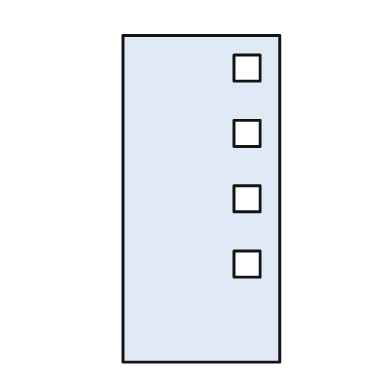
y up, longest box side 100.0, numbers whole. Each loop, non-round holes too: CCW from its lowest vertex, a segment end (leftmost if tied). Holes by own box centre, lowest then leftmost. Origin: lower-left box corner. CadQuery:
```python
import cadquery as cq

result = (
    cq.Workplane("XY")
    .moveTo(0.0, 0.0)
    .lineTo(48.0, 0.0)
    .lineTo(48.0, 100.0)
    .lineTo(0.0, 100.0)
    .close()
    .moveTo(34.0, 26.0)
    .lineTo(42.0, 26.0)
    .lineTo(42.0, 34.0)
    .lineTo(34.0, 34.0)
    .close()
    .moveTo(34.0, 46.0)
    .lineTo(42.0, 46.0)
    .lineTo(42.0, 54.0)
    .lineTo(34.0, 54.0)
    .close()
    .moveTo(34.0, 66.0)
    .lineTo(42.0, 66.0)
    .lineTo(42.0, 74.0)
    .lineTo(34.0, 74.0)
    .close()
    .moveTo(34.0, 86.0)
    .lineTo(42.0, 86.0)
    .lineTo(42.0, 94.0)
    .lineTo(34.0, 94.0)
    .close()
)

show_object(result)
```